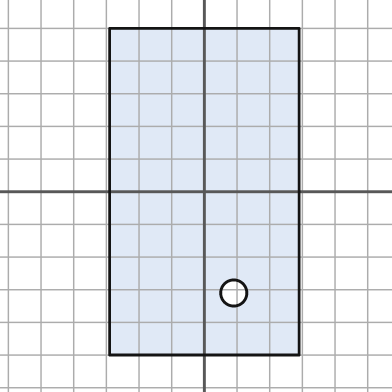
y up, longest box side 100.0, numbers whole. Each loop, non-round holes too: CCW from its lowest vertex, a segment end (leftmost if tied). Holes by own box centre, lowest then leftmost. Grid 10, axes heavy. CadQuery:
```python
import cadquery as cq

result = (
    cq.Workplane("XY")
    .moveTo(-29.0, -50.0)
    .lineTo(29.0, -50.0)
    .lineTo(29.0, 50.0)
    .lineTo(-29.0, 50.0)
    .close()
    .moveTo(9.0, -31.0)
    .circle(4.0)
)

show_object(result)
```